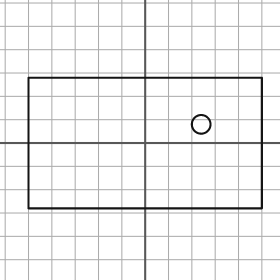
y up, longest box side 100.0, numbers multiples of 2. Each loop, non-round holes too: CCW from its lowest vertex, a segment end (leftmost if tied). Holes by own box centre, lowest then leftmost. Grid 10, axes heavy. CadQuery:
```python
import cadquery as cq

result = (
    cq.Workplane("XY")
    .moveTo(-50.0, -28.0)
    .lineTo(50.0, -28.0)
    .lineTo(50.0, 28.0)
    .lineTo(-50.0, 28.0)
    .close()
    .moveTo(24.0, 8.0)
    .circle(4.0)
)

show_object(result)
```